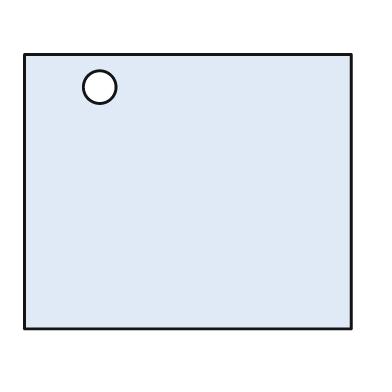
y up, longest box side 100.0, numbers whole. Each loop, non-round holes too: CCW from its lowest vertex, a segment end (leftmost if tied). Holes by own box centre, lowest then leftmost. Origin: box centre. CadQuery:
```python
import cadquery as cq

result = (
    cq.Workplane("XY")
    .moveTo(-50.0, -42.0)
    .lineTo(50.0, -42.0)
    .lineTo(50.0, 42.0)
    .lineTo(-50.0, 42.0)
    .close()
    .moveTo(-27.0, 32.0)
    .circle(5.0)
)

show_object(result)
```